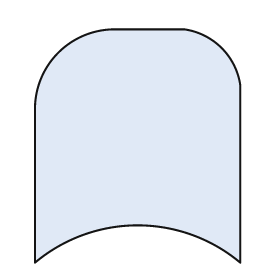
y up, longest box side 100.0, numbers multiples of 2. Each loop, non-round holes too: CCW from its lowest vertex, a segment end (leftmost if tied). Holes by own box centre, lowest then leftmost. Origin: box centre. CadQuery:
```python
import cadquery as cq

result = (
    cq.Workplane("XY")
    .moveTo(-44.0, -50.0)
    .threePointArc((0.0, -34.0), (44.0, -50.0))
    .lineTo(44.0, 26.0)
    .threePointArc((36.0, 42.0), (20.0, 50.0))
    .lineTo(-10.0, 50.0)
    .threePointArc((-34.0, 40.0), (-44.0, 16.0))
    .close()
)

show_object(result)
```